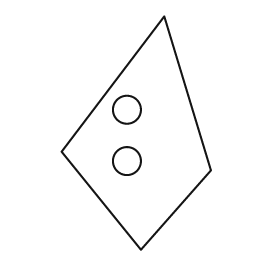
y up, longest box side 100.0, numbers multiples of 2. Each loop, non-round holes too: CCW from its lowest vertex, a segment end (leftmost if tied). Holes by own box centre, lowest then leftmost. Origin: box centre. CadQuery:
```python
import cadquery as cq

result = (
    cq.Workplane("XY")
    .moveTo(2.0, -50.0)
    .lineTo(32.0, -16.0)
    .lineTo(12.0, 50.0)
    .lineTo(-32.0, -8.0)
    .close()
    .moveTo(-4.0, -12.0)
    .circle(6.0)
    .moveTo(-4.0, 10.0)
    .circle(6.0)
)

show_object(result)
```